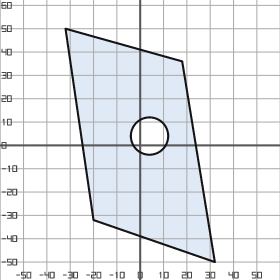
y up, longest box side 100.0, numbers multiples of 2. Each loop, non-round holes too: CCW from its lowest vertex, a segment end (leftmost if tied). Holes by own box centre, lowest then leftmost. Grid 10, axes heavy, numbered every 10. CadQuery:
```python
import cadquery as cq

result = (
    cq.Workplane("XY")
    .moveTo(32.0, -50.0)
    .lineTo(18.0, 36.0)
    .lineTo(-32.0, 50.0)
    .lineTo(-20.0, -32.0)
    .close()
    .moveTo(4.0, 4.0)
    .circle(8.0)
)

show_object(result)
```